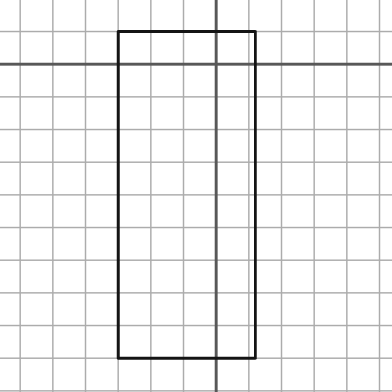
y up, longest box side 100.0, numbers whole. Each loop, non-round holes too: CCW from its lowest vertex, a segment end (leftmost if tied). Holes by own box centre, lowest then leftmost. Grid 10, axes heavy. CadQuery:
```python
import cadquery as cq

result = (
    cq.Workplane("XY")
    .moveTo(-30.0, -90.0)
    .lineTo(12.0, -90.0)
    .lineTo(12.0, 10.0)
    .lineTo(-30.0, 10.0)
    .close()
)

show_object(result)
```